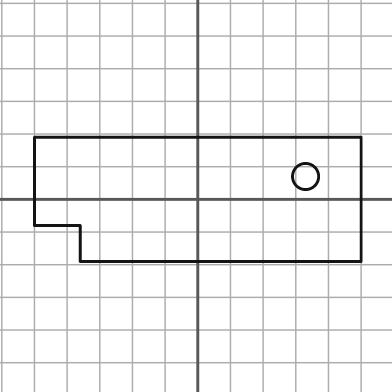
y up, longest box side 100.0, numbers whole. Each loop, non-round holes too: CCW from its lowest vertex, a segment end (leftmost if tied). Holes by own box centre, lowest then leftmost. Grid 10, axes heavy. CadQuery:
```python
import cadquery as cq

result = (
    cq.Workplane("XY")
    .moveTo(-36.0, -19.0)
    .lineTo(50.0, -19.0)
    .lineTo(50.0, 19.0)
    .lineTo(-50.0, 19.0)
    .lineTo(-50.0, -8.0)
    .lineTo(-36.0, -8.0)
    .close()
    .moveTo(33.0, 7.0)
    .circle(4.0)
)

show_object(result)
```